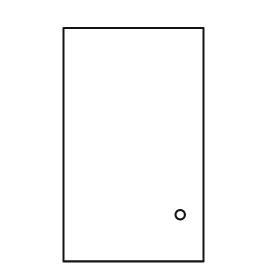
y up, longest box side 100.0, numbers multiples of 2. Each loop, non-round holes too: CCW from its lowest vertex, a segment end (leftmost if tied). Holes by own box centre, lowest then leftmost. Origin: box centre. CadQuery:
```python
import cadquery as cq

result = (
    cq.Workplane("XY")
    .moveTo(-30.0, -50.0)
    .lineTo(30.0, -50.0)
    .lineTo(30.0, 50.0)
    .lineTo(-30.0, 50.0)
    .close()
    .moveTo(20.0, -30.0)
    .circle(2.0)
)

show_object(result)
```